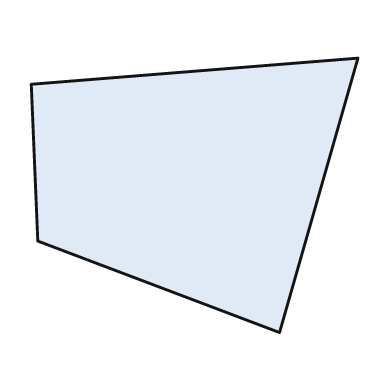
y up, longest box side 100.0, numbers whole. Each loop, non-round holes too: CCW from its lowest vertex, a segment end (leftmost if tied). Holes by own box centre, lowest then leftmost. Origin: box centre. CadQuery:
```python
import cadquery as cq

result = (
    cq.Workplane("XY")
    .moveTo(26.0, -42.0)
    .lineTo(50.0, 42.0)
    .lineTo(-50.0, 34.0)
    .lineTo(-48.0, -14.0)
    .close()
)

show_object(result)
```